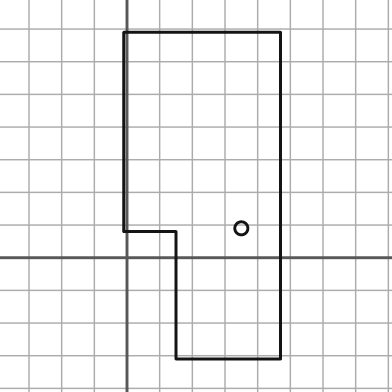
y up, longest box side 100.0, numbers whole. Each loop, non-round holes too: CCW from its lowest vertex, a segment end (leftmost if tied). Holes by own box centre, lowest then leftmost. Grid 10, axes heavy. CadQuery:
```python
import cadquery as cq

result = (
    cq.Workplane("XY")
    .moveTo(15.0, -31.0)
    .lineTo(47.0, -31.0)
    .lineTo(47.0, 69.0)
    .lineTo(-1.0, 69.0)
    .lineTo(-1.0, 8.0)
    .lineTo(15.0, 8.0)
    .close()
    .moveTo(35.0, 9.0)
    .circle(2.0)
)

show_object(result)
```